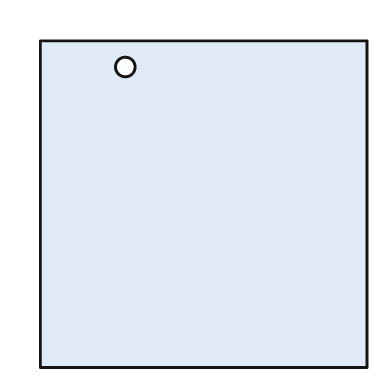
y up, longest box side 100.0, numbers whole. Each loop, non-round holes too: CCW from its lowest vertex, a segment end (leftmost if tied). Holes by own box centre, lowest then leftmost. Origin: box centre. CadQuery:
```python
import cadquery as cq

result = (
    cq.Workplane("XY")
    .moveTo(-50.0, -50.0)
    .lineTo(50.0, -50.0)
    .lineTo(50.0, 50.0)
    .lineTo(-50.0, 50.0)
    .close()
    .moveTo(-24.0, 42.0)
    .circle(3.0)
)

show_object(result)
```